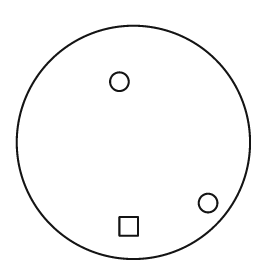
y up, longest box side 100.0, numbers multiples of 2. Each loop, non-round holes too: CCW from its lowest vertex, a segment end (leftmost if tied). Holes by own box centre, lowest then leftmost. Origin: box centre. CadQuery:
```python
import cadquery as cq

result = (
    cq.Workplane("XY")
    .moveTo(0.0, 0.0)
    .circle(50.0)
    .moveTo(-6.0, -40.0)
    .lineTo(2.0, -40.0)
    .lineTo(2.0, -32.0)
    .lineTo(-6.0, -32.0)
    .close()
    .moveTo(32.0, -26.0)
    .circle(4.0)
    .moveTo(-6.0, 26.0)
    .circle(4.0)
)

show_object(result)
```